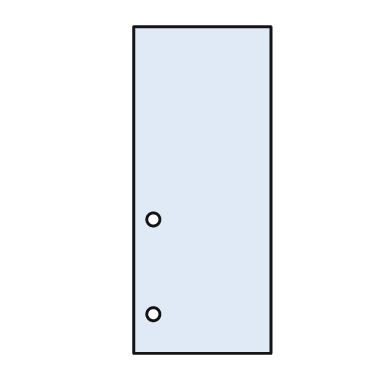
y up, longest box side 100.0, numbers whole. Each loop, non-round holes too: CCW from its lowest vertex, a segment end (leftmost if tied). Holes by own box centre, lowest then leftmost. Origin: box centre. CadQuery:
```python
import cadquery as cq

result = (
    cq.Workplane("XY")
    .moveTo(-21.0, -50.0)
    .lineTo(21.0, -50.0)
    .lineTo(21.0, 50.0)
    .lineTo(-21.0, 50.0)
    .close()
    .moveTo(-15.0, -38.0)
    .circle(2.0)
    .moveTo(-15.0, -9.0)
    .circle(2.0)
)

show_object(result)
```